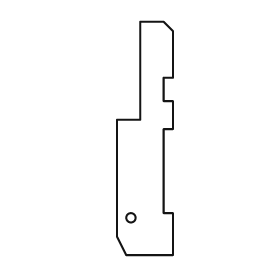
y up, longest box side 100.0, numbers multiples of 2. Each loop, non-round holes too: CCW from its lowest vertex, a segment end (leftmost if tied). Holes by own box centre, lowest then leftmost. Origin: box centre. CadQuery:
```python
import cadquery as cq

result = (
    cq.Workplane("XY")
    .moveTo(-8.0, -50.0)
    .lineTo(12.0, -50.0)
    .lineTo(12.0, -32.0)
    .lineTo(8.0, -32.0)
    .lineTo(8.0, 4.0)
    .lineTo(12.0, 4.0)
    .lineTo(12.0, 16.0)
    .lineTo(8.0, 16.0)
    .lineTo(8.0, 26.0)
    .lineTo(12.0, 26.0)
    .lineTo(12.0, 46.0)
    .lineTo(8.0, 50.0)
    .lineTo(-2.0, 50.0)
    .lineTo(-2.0, 8.0)
    .lineTo(-12.0, 8.0)
    .lineTo(-12.0, -42.0)
    .close()
    .moveTo(-6.0, -34.0)
    .circle(2.0)
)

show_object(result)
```